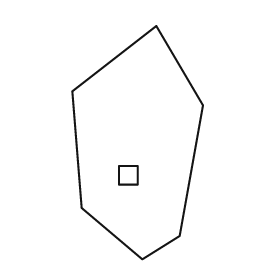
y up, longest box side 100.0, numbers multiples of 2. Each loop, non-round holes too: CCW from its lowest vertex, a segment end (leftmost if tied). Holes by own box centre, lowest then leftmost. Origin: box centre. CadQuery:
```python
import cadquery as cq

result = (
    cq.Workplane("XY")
    .moveTo(2.0, -50.0)
    .lineTo(18.0, -40.0)
    .lineTo(28.0, 16.0)
    .lineTo(8.0, 50.0)
    .lineTo(-28.0, 22.0)
    .lineTo(-24.0, -28.0)
    .close()
    .moveTo(-8.0, -18.0)
    .lineTo(0.0, -18.0)
    .lineTo(0.0, -10.0)
    .lineTo(-8.0, -10.0)
    .close()
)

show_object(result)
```